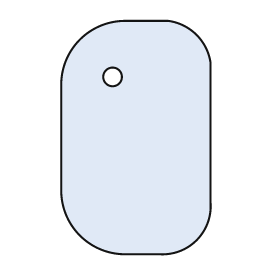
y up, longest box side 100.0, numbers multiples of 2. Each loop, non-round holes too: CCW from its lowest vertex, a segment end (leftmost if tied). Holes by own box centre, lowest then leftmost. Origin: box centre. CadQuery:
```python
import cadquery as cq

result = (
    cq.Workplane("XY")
    .moveTo(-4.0, -50.0)
    .lineTo(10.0, -50.0)
    .threePointArc((26.0, -44.0), (32.0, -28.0))
    .lineTo(32.0, 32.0)
    .threePointArc((26.0, 44.0), (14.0, 50.0))
    .lineTo(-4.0, 50.0)
    .threePointArc((-24.0, 42.0), (-32.0, 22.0))
    .lineTo(-32.0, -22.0)
    .threePointArc((-24.0, -42.0), (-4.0, -50.0))
    .close()
    .moveTo(-10.0, 26.0)
    .circle(4.0)
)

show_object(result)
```